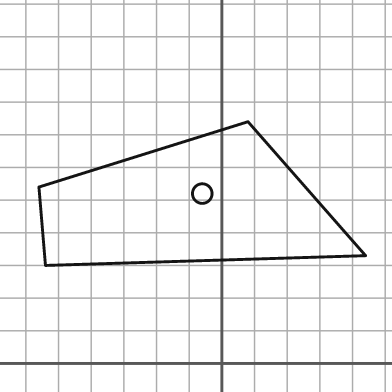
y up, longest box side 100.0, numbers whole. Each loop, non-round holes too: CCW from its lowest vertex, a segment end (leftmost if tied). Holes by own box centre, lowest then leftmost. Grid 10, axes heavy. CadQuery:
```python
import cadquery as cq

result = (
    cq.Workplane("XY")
    .moveTo(-54.0, 30.0)
    .lineTo(44.0, 33.0)
    .lineTo(8.0, 74.0)
    .lineTo(-56.0, 54.0)
    .close()
    .moveTo(-6.0, 52.0)
    .circle(3.0)
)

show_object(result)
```